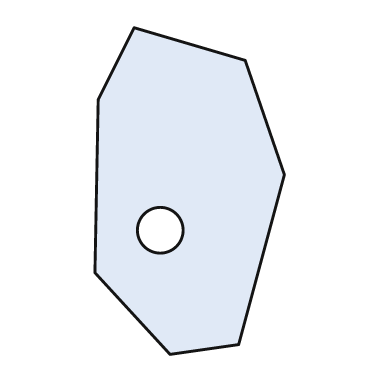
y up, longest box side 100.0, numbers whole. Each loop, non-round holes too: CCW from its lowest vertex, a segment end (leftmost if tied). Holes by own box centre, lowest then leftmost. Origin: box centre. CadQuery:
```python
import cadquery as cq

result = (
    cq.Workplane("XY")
    .moveTo(-6.0, -50.0)
    .lineTo(15.0, -47.0)
    .lineTo(29.0, 5.0)
    .lineTo(17.0, 40.0)
    .lineTo(-17.0, 50.0)
    .lineTo(-28.0, 28.0)
    .lineTo(-29.0, -25.0)
    .close()
    .moveTo(-9.0, -12.0)
    .circle(7.0)
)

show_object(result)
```